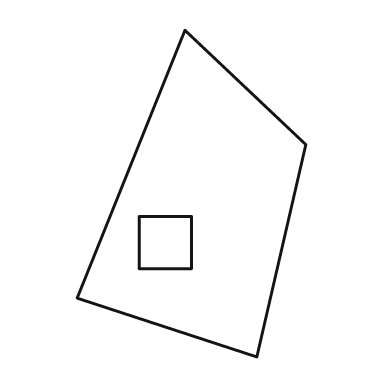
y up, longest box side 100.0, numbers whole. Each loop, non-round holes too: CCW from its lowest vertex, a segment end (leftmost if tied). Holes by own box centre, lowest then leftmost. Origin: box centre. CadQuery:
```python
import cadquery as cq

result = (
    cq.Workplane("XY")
    .moveTo(20.0, -50.0)
    .lineTo(35.0, 15.0)
    .lineTo(-2.0, 50.0)
    .lineTo(-35.0, -32.0)
    .close()
    .moveTo(-16.0, -23.0)
    .lineTo(0.0, -23.0)
    .lineTo(0.0, -7.0)
    .lineTo(-16.0, -7.0)
    .close()
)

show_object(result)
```